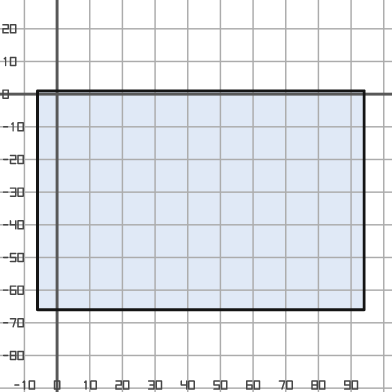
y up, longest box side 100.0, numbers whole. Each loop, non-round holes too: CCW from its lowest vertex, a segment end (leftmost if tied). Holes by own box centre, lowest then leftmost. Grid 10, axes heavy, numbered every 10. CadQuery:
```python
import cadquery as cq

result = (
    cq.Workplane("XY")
    .moveTo(-6.0, -66.0)
    .lineTo(94.0, -66.0)
    .lineTo(94.0, 1.0)
    .lineTo(-6.0, 1.0)
    .close()
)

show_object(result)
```